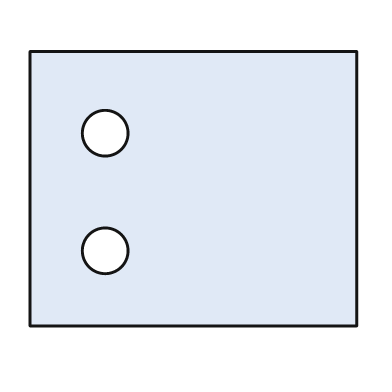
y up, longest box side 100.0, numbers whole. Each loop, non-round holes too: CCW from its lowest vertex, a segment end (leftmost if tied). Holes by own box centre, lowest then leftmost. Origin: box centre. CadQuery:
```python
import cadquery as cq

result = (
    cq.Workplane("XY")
    .moveTo(-50.0, -42.0)
    .lineTo(50.0, -42.0)
    .lineTo(50.0, 42.0)
    .lineTo(-50.0, 42.0)
    .close()
    .moveTo(-27.0, -19.0)
    .circle(7.0)
    .moveTo(-27.0, 17.0)
    .circle(7.0)
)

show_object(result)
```